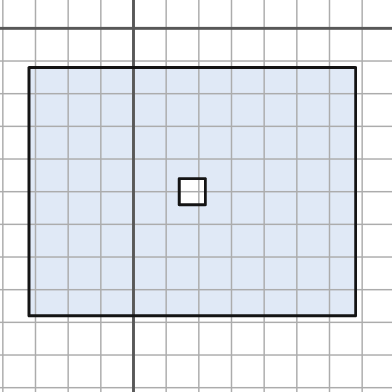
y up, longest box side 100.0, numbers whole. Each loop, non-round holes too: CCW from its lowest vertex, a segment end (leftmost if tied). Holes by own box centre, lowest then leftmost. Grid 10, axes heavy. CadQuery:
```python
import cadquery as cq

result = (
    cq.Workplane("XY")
    .moveTo(-32.0, -88.0)
    .lineTo(68.0, -88.0)
    .lineTo(68.0, -12.0)
    .lineTo(-32.0, -12.0)
    .close()
    .moveTo(14.0, -54.0)
    .lineTo(22.0, -54.0)
    .lineTo(22.0, -46.0)
    .lineTo(14.0, -46.0)
    .close()
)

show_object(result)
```